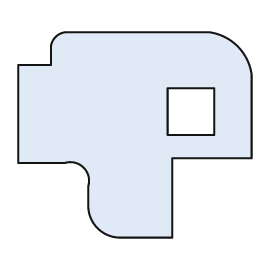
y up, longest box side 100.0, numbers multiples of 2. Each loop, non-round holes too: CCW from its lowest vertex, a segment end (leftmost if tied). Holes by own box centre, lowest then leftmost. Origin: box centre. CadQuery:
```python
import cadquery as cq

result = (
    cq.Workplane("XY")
    .moveTo(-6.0, -44.0)
    .lineTo(16.0, -44.0)
    .lineTo(16.0, -10.0)
    .lineTo(50.0, -10.0)
    .lineTo(50.0, 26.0)
    .threePointArc((44.0, 38.0), (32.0, 44.0))
    .lineTo(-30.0, 44.0)
    .threePointArc((-34.0, 42.0), (-36.0, 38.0))
    .lineTo(-36.0, 30.0)
    .lineTo(-50.0, 30.0)
    .lineTo(-50.0, -12.0)
    .lineTo(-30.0, -12.0)
    .threePointArc((-22.0, -14.0), (-20.0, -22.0))
    .lineTo(-20.0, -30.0)
    .threePointArc((-16.0, -40.0), (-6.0, -44.0))
    .close()
    .moveTo(14.0, 0.0)
    .lineTo(34.0, 0.0)
    .lineTo(34.0, 20.0)
    .lineTo(14.0, 20.0)
    .close()
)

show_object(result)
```